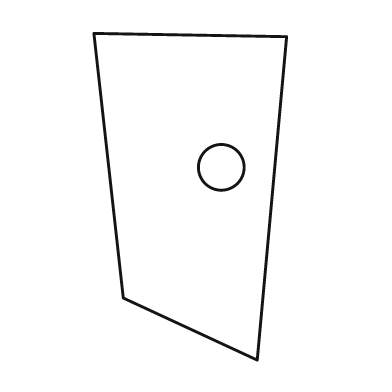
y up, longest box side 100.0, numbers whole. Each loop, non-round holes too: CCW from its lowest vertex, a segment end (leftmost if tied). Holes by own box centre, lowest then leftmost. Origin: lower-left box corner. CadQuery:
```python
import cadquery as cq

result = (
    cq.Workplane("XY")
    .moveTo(50.0, 0.0)
    .lineTo(59.0, 99.0)
    .lineTo(0.0, 100.0)
    .lineTo(9.0, 19.0)
    .close()
    .moveTo(39.0, 59.0)
    .circle(7.0)
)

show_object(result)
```